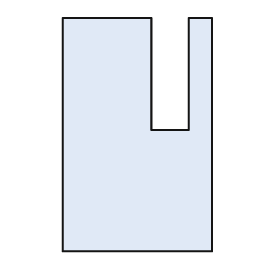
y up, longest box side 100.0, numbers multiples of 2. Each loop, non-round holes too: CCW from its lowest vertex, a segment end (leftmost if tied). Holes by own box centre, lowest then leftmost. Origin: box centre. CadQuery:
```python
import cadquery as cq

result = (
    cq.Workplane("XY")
    .moveTo(-32.0, -50.0)
    .lineTo(32.0, -50.0)
    .lineTo(32.0, 50.0)
    .lineTo(22.0, 50.0)
    .lineTo(22.0, 2.0)
    .lineTo(6.0, 2.0)
    .lineTo(6.0, 50.0)
    .lineTo(-32.0, 50.0)
    .close()
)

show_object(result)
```